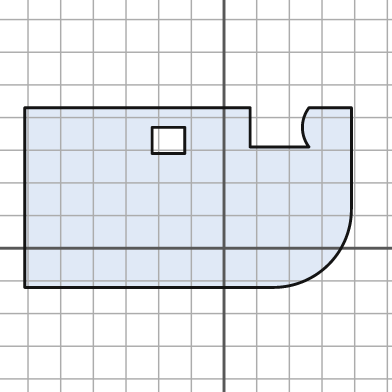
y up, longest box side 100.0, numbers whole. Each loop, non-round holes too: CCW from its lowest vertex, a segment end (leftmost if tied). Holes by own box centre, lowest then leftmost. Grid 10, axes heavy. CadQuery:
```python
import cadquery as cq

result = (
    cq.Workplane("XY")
    .moveTo(-61.0, -12.0)
    .lineTo(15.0, -12.0)
    .threePointArc((32.0, -5.0), (39.0, 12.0))
    .lineTo(39.0, 43.0)
    .lineTo(26.0, 43.0)
    .threePointArc((24.0, 37.0), (26.0, 31.0))
    .lineTo(8.0, 31.0)
    .lineTo(8.0, 43.0)
    .lineTo(-61.0, 43.0)
    .close()
    .moveTo(-22.0, 29.0)
    .lineTo(-12.0, 29.0)
    .lineTo(-12.0, 37.0)
    .lineTo(-22.0, 37.0)
    .close()
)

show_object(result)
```